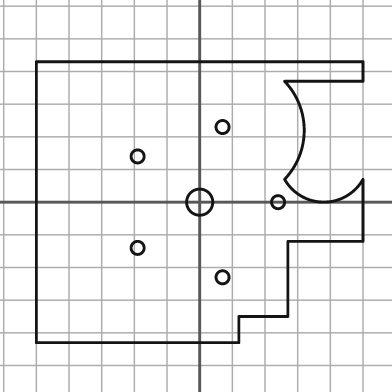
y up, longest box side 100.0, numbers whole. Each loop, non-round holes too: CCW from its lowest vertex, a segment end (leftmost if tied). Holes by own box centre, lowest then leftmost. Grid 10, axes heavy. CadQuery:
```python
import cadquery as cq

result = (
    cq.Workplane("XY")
    .moveTo(-50.0, -43.0)
    .lineTo(12.0, -43.0)
    .lineTo(12.0, -35.0)
    .lineTo(27.0, -35.0)
    .lineTo(27.0, -12.0)
    .lineTo(50.0, -12.0)
    .lineTo(50.0, 7.0)
    .threePointArc((38.0, 0.0), (26.0, 7.0))
    .threePointArc((32.0, 22.0), (26.0, 37.0))
    .lineTo(50.0, 37.0)
    .lineTo(50.0, 43.0)
    .lineTo(-50.0, 43.0)
    .close()
    .moveTo(7.0, -23.0)
    .circle(2.0)
    .moveTo(-19.0, -14.0)
    .circle(2.0)
    .moveTo(0.0, 0.0)
    .circle(4.0)
    .moveTo(24.0, 0.0)
    .circle(2.0)
    .moveTo(-19.0, 14.0)
    .circle(2.0)
    .moveTo(7.0, 23.0)
    .circle(2.0)
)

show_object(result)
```